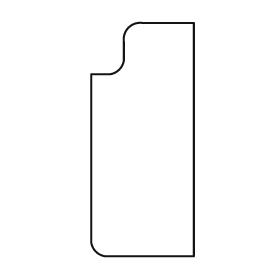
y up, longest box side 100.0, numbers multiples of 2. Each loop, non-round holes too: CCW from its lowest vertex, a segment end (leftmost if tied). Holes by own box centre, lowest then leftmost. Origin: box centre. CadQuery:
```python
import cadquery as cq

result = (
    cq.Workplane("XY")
    .moveTo(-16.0, -50.0)
    .lineTo(22.0, -50.0)
    .lineTo(22.0, 50.0)
    .lineTo(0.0, 50.0)
    .threePointArc((-6.0, 48.0), (-8.0, 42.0))
    .lineTo(-8.0, 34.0)
    .threePointArc((-10.0, 30.0), (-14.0, 28.0))
    .lineTo(-22.0, 28.0)
    .lineTo(-22.0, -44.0)
    .threePointArc((-20.0, -48.0), (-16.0, -50.0))
    .close()
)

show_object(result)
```